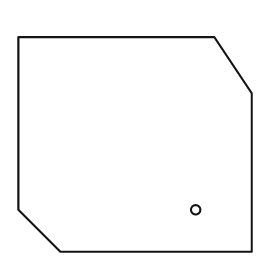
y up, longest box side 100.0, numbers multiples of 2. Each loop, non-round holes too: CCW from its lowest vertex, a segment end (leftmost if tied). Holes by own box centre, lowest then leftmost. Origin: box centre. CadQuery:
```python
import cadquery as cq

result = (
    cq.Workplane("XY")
    .moveTo(-32.0, -46.0)
    .lineTo(50.0, -46.0)
    .lineTo(50.0, 22.0)
    .lineTo(34.0, 46.0)
    .lineTo(-50.0, 46.0)
    .lineTo(-50.0, -28.0)
    .close()
    .moveTo(26.0, -28.0)
    .circle(2.0)
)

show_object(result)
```